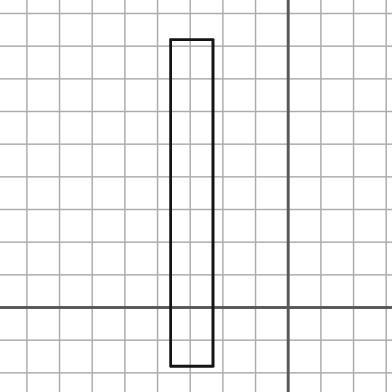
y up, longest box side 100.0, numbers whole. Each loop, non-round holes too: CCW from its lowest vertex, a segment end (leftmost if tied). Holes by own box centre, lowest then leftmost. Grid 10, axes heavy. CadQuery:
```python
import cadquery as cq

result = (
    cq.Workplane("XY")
    .moveTo(-36.0, -18.0)
    .lineTo(-23.0, -18.0)
    .lineTo(-23.0, 82.0)
    .lineTo(-36.0, 82.0)
    .close()
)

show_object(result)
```